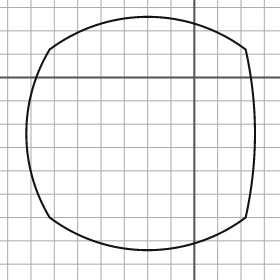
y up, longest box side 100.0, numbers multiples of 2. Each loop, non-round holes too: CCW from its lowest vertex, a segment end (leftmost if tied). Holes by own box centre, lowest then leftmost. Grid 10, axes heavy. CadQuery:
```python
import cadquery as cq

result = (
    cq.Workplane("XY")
    .moveTo(-62.0, -60.0)
    .threePointArc((-20.0, -74.0), (22.0, -60.0))
    .threePointArc((26.0, -24.0), (22.0, 12.0))
    .threePointArc((-20.0, 26.0), (-62.0, 12.0))
    .threePointArc((-72.0, -24.0), (-62.0, -60.0))
    .close()
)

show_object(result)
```